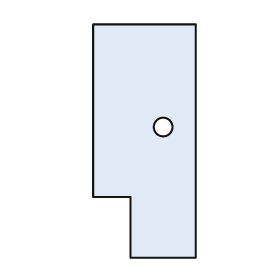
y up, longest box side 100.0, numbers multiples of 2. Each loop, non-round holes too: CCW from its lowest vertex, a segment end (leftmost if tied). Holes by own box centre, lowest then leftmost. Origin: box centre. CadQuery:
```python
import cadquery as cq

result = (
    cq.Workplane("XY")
    .moveTo(-6.0, -50.0)
    .lineTo(22.0, -50.0)
    .lineTo(22.0, 50.0)
    .lineTo(-22.0, 50.0)
    .lineTo(-22.0, -24.0)
    .lineTo(-6.0, -24.0)
    .close()
    .moveTo(8.0, 6.0)
    .circle(4.0)
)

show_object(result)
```